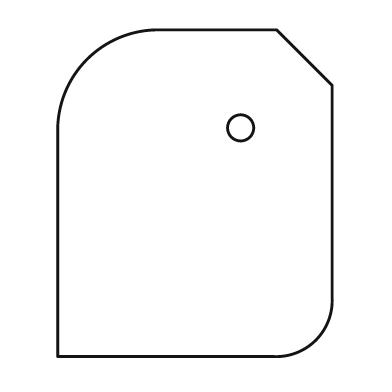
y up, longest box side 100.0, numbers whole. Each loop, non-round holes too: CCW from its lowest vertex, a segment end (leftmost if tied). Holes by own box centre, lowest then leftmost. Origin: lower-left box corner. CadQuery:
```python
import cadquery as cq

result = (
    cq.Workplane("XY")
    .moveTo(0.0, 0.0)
    .lineTo(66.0, 0.0)
    .threePointArc((79.0, 5.0), (84.0, 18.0))
    .lineTo(84.0, 83.0)
    .lineTo(67.0, 100.0)
    .lineTo(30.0, 100.0)
    .threePointArc((9.0, 91.0), (0.0, 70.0))
    .close()
    .moveTo(56.0, 70.0)
    .circle(4.0)
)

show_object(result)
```